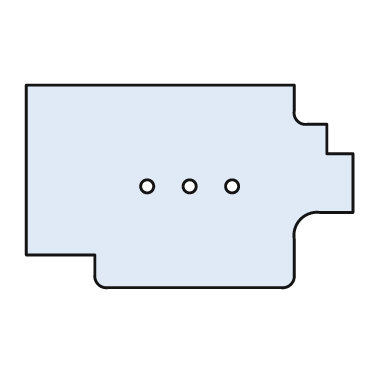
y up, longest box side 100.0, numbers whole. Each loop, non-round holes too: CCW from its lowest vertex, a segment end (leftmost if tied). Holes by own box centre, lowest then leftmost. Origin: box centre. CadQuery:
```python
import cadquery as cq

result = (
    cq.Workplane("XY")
    .moveTo(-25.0, -31.0)
    .lineTo(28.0, -31.0)
    .threePointArc((31.0, -30.0), (32.0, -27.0))
    .lineTo(32.0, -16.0)
    .threePointArc((34.0, -10.0), (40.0, -8.0))
    .lineTo(50.0, -8.0)
    .lineTo(50.0, 10.0)
    .lineTo(42.0, 10.0)
    .lineTo(42.0, 19.0)
    .lineTo(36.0, 19.0)
    .threePointArc((33.0, 20.0), (32.0, 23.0))
    .lineTo(32.0, 31.0)
    .lineTo(-50.0, 31.0)
    .lineTo(-50.0, -21.0)
    .lineTo(-29.0, -21.0)
    .lineTo(-29.0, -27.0)
    .threePointArc((-28.0, -30.0), (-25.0, -31.0))
    .close()
    .moveTo(-13.0, 0.0)
    .circle(2.0)
    .moveTo(0.0, 0.0)
    .circle(2.0)
    .moveTo(13.0, 0.0)
    .circle(2.0)
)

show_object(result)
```